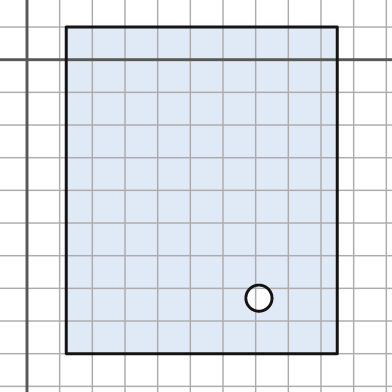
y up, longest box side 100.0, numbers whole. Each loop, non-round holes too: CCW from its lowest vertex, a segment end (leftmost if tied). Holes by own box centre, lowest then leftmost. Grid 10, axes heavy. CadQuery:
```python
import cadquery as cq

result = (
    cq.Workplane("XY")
    .moveTo(12.0, -90.0)
    .lineTo(95.0, -90.0)
    .lineTo(95.0, 10.0)
    .lineTo(12.0, 10.0)
    .close()
    .moveTo(71.0, -73.0)
    .circle(4.0)
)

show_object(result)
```